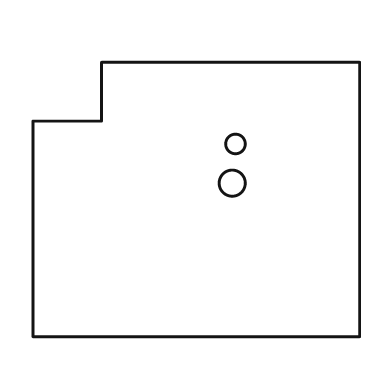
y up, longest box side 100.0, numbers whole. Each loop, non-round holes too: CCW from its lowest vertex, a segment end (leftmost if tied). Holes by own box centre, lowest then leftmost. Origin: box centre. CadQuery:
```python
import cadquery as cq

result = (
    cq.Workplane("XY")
    .moveTo(-50.0, -42.0)
    .lineTo(50.0, -42.0)
    .lineTo(50.0, 42.0)
    .lineTo(-29.0, 42.0)
    .lineTo(-29.0, 24.0)
    .lineTo(-50.0, 24.0)
    .close()
    .moveTo(11.0, 5.0)
    .circle(4.0)
    .moveTo(12.0, 17.0)
    .circle(3.0)
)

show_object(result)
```